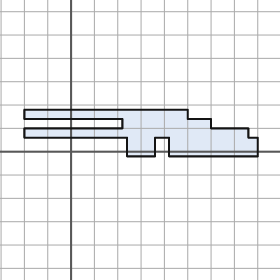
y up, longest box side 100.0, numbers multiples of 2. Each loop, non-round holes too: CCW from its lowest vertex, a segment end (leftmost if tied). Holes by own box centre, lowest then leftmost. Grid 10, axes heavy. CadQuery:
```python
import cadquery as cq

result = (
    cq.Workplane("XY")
    .moveTo(24.0, -2.0)
    .lineTo(36.0, -2.0)
    .lineTo(36.0, 6.0)
    .lineTo(42.0, 6.0)
    .lineTo(42.0, -2.0)
    .lineTo(80.0, -2.0)
    .lineTo(80.0, 6.0)
    .lineTo(76.0, 6.0)
    .lineTo(76.0, 10.0)
    .lineTo(60.0, 10.0)
    .lineTo(60.0, 14.0)
    .lineTo(50.0, 14.0)
    .lineTo(50.0, 18.0)
    .lineTo(-20.0, 18.0)
    .lineTo(-20.0, 14.0)
    .lineTo(22.0, 14.0)
    .lineTo(22.0, 10.0)
    .lineTo(-20.0, 10.0)
    .lineTo(-20.0, 6.0)
    .lineTo(24.0, 6.0)
    .close()
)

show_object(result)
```